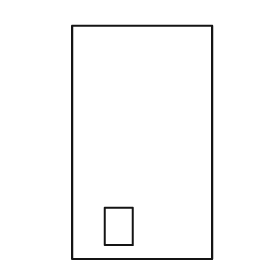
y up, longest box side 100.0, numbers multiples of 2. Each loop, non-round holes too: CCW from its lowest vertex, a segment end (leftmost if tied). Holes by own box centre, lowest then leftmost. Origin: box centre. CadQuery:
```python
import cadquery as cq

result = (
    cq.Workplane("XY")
    .moveTo(-30.0, -50.0)
    .lineTo(30.0, -50.0)
    .lineTo(30.0, 50.0)
    .lineTo(-30.0, 50.0)
    .close()
    .moveTo(-16.0, -44.0)
    .lineTo(-4.0, -44.0)
    .lineTo(-4.0, -28.0)
    .lineTo(-16.0, -28.0)
    .close()
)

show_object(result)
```